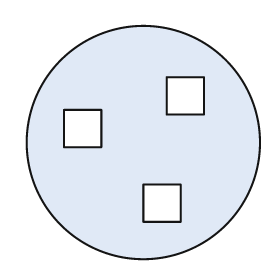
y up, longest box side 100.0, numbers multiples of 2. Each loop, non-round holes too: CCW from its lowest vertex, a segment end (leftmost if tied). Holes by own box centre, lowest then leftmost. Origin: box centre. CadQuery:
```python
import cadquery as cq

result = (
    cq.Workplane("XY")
    .moveTo(0.0, 0.0)
    .circle(50.0)
    .moveTo(0.0, -34.0)
    .lineTo(16.0, -34.0)
    .lineTo(16.0, -18.0)
    .lineTo(0.0, -18.0)
    .close()
    .moveTo(-34.0, -2.0)
    .lineTo(-18.0, -2.0)
    .lineTo(-18.0, 14.0)
    .lineTo(-34.0, 14.0)
    .close()
    .moveTo(10.0, 12.0)
    .lineTo(26.0, 12.0)
    .lineTo(26.0, 28.0)
    .lineTo(10.0, 28.0)
    .close()
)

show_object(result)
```